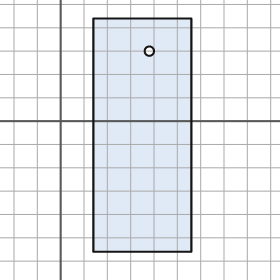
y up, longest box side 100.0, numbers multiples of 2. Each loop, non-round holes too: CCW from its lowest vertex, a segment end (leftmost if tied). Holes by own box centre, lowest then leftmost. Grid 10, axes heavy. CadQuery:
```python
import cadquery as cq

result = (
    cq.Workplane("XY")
    .moveTo(14.0, -56.0)
    .lineTo(56.0, -56.0)
    .lineTo(56.0, 44.0)
    .lineTo(14.0, 44.0)
    .close()
    .moveTo(38.0, 30.0)
    .circle(2.0)
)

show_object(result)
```